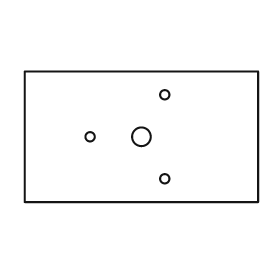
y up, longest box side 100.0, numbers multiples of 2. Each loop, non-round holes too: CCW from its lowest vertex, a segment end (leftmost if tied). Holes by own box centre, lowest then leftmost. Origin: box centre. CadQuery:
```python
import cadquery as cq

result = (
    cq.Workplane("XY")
    .moveTo(-50.0, -28.0)
    .lineTo(50.0, -28.0)
    .lineTo(50.0, 28.0)
    .lineTo(-50.0, 28.0)
    .close()
    .moveTo(10.0, -18.0)
    .circle(2.0)
    .moveTo(-22.0, 0.0)
    .circle(2.0)
    .moveTo(0.0, 0.0)
    .circle(4.0)
    .moveTo(10.0, 18.0)
    .circle(2.0)
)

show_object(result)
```